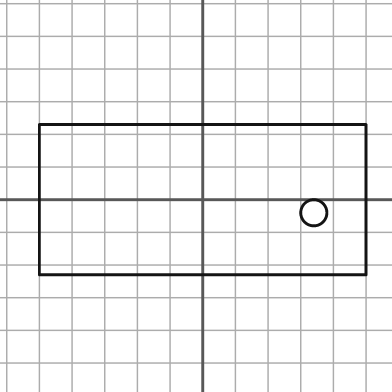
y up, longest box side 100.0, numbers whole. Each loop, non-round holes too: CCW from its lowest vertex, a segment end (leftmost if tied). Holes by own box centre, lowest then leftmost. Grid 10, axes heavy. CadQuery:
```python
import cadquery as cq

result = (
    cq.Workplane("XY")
    .moveTo(-50.0, -23.0)
    .lineTo(50.0, -23.0)
    .lineTo(50.0, 23.0)
    .lineTo(-50.0, 23.0)
    .close()
    .moveTo(34.0, -4.0)
    .circle(4.0)
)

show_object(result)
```